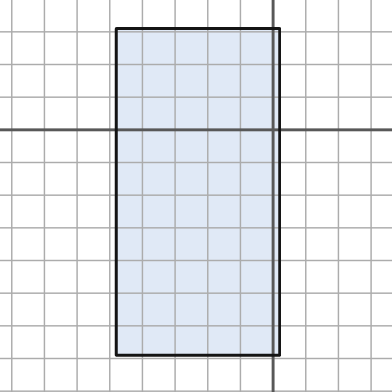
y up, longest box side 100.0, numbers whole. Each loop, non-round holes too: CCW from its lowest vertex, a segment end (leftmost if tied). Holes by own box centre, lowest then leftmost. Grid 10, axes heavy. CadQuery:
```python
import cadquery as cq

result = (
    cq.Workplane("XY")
    .moveTo(-48.0, -69.0)
    .lineTo(2.0, -69.0)
    .lineTo(2.0, 31.0)
    .lineTo(-48.0, 31.0)
    .close()
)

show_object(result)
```